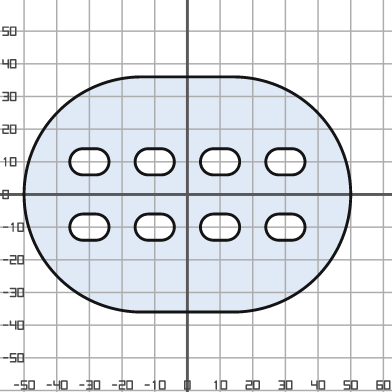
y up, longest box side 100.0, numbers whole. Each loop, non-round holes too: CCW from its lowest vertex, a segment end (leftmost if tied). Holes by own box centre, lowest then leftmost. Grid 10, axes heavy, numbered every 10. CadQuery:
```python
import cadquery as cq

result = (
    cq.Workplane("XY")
    .moveTo(-14.0, -36.0)
    .lineTo(14.0, -36.0)
    .threePointArc((50.0, 0.0), (14.0, 36.0))
    .lineTo(-14.0, 36.0)
    .threePointArc((-50.0, 0.0), (-14.0, -36.0))
    .close()
    .moveTo(-32.0, -14.0)
    .lineTo(-28.0, -14.0)
    .threePointArc((-24.0, -10.0), (-28.0, -6.0))
    .lineTo(-32.0, -6.0)
    .threePointArc((-36.0, -10.0), (-32.0, -14.0))
    .close()
    .moveTo(-12.0, -14.0)
    .lineTo(-8.0, -14.0)
    .threePointArc((-4.0, -10.0), (-8.0, -6.0))
    .lineTo(-12.0, -6.0)
    .threePointArc((-16.0, -10.0), (-12.0, -14.0))
    .close()
    .moveTo(8.0, -14.0)
    .lineTo(12.0, -14.0)
    .threePointArc((16.0, -10.0), (12.0, -6.0))
    .lineTo(8.0, -6.0)
    .threePointArc((4.0, -10.0), (8.0, -14.0))
    .close()
    .moveTo(28.0, -14.0)
    .lineTo(32.0, -14.0)
    .threePointArc((36.0, -10.0), (32.0, -6.0))
    .lineTo(28.0, -6.0)
    .threePointArc((24.0, -10.0), (28.0, -14.0))
    .close()
    .moveTo(-32.0, 6.0)
    .lineTo(-28.0, 6.0)
    .threePointArc((-24.0, 10.0), (-28.0, 14.0))
    .lineTo(-32.0, 14.0)
    .threePointArc((-36.0, 10.0), (-32.0, 6.0))
    .close()
    .moveTo(-12.0, 6.0)
    .lineTo(-8.0, 6.0)
    .threePointArc((-4.0, 10.0), (-8.0, 14.0))
    .lineTo(-12.0, 14.0)
    .threePointArc((-16.0, 10.0), (-12.0, 6.0))
    .close()
    .moveTo(8.0, 6.0)
    .lineTo(12.0, 6.0)
    .threePointArc((16.0, 10.0), (12.0, 14.0))
    .lineTo(8.0, 14.0)
    .threePointArc((4.0, 10.0), (8.0, 6.0))
    .close()
    .moveTo(28.0, 6.0)
    .lineTo(32.0, 6.0)
    .threePointArc((36.0, 10.0), (32.0, 14.0))
    .lineTo(28.0, 14.0)
    .threePointArc((24.0, 10.0), (28.0, 6.0))
    .close()
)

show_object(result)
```